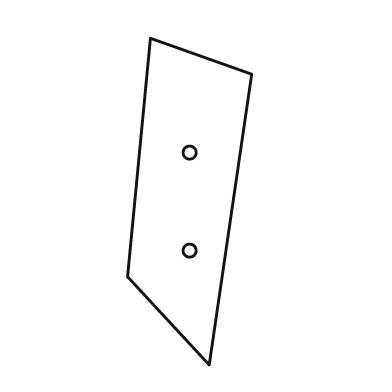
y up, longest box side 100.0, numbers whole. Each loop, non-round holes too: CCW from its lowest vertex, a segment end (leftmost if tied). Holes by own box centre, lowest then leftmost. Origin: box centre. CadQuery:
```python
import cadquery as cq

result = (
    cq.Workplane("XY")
    .moveTo(6.0, -50.0)
    .lineTo(19.0, 39.0)
    .lineTo(-12.0, 50.0)
    .lineTo(-19.0, -23.0)
    .close()
    .moveTo(0.0, -15.0)
    .circle(2.0)
    .moveTo(0.0, 15.0)
    .circle(2.0)
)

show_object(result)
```